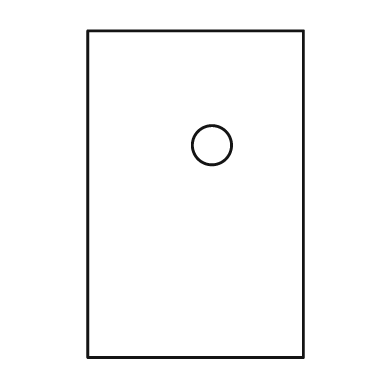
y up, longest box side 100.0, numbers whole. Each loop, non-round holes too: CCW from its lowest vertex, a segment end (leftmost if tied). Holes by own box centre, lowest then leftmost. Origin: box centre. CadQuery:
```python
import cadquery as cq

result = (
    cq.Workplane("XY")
    .moveTo(-33.0, -50.0)
    .lineTo(33.0, -50.0)
    .lineTo(33.0, 50.0)
    .lineTo(-33.0, 50.0)
    .close()
    .moveTo(5.0, 15.0)
    .circle(6.0)
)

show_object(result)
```